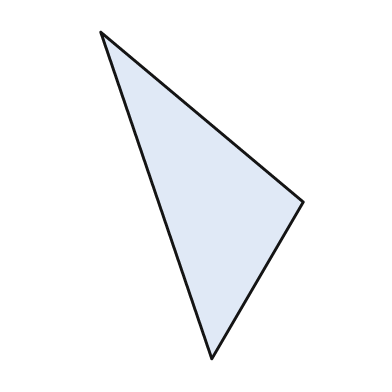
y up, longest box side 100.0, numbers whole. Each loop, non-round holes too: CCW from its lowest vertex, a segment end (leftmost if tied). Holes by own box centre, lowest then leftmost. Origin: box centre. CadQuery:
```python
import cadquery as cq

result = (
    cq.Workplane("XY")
    .moveTo(3.0, -50.0)
    .lineTo(31.0, -2.0)
    .lineTo(-31.0, 50.0)
    .close()
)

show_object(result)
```